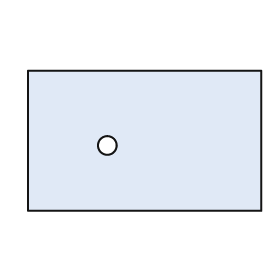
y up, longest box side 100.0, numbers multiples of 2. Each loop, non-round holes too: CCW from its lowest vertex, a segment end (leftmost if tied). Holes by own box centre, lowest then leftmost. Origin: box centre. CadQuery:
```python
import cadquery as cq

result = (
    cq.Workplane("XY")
    .moveTo(-50.0, -30.0)
    .lineTo(50.0, -30.0)
    .lineTo(50.0, 30.0)
    .lineTo(-50.0, 30.0)
    .close()
    .moveTo(-16.0, -2.0)
    .circle(4.0)
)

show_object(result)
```